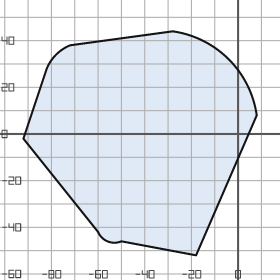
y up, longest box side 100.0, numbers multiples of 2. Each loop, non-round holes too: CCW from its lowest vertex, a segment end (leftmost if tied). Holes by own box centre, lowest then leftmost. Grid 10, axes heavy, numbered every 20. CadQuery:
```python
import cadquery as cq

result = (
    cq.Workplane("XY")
    .moveTo(-18.0, -52.0)
    .lineTo(8.0, 8.0)
    .threePointArc((-4.0, 32.0), (-28.0, 44.0))
    .lineTo(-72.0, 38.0)
    .threePointArc((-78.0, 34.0), (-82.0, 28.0))
    .lineTo(-92.0, -2.0)
    .lineTo(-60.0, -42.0)
    .threePointArc((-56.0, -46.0), (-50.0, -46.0))
    .close()
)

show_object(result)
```